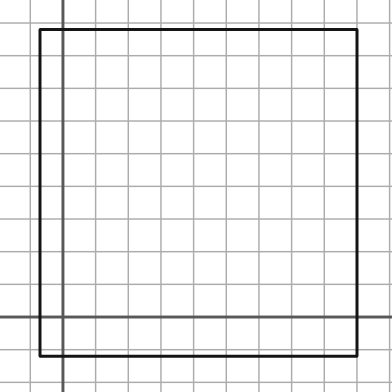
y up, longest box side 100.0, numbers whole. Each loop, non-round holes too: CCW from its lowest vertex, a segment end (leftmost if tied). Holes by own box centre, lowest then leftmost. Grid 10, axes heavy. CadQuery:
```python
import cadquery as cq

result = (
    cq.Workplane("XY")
    .moveTo(-7.0, -12.0)
    .lineTo(90.0, -12.0)
    .lineTo(90.0, 88.0)
    .lineTo(-7.0, 88.0)
    .close()
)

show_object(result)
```